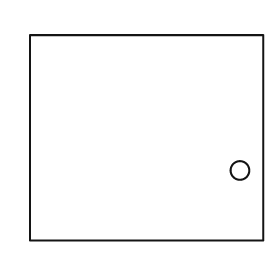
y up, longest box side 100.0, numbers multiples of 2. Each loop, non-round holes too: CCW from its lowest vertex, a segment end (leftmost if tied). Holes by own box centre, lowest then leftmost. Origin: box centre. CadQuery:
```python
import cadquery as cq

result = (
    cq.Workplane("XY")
    .moveTo(-50.0, -44.0)
    .lineTo(50.0, -44.0)
    .lineTo(50.0, 44.0)
    .lineTo(-50.0, 44.0)
    .close()
    .moveTo(40.0, -14.0)
    .circle(4.0)
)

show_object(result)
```